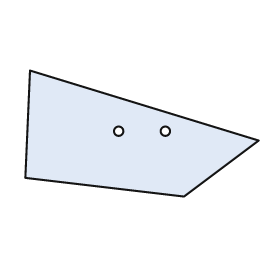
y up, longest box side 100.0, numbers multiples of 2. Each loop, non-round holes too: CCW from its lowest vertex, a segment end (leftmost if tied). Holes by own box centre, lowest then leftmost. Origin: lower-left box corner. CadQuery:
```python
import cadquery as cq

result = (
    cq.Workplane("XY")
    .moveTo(68.0, 0.0)
    .lineTo(100.0, 24.0)
    .lineTo(2.0, 54.0)
    .lineTo(0.0, 8.0)
    .close()
    .moveTo(40.0, 28.0)
    .circle(2.0)
    .moveTo(60.0, 28.0)
    .circle(2.0)
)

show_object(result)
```